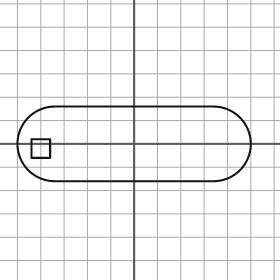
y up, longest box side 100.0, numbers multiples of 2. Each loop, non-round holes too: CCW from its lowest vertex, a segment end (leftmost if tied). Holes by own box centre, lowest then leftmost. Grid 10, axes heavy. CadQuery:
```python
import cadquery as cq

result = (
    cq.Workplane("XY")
    .moveTo(-34.0, -16.0)
    .lineTo(34.0, -16.0)
    .threePointArc((50.0, 0.0), (34.0, 16.0))
    .lineTo(-34.0, 16.0)
    .threePointArc((-50.0, 0.0), (-34.0, -16.0))
    .close()
    .moveTo(-44.0, -6.0)
    .lineTo(-36.0, -6.0)
    .lineTo(-36.0, 2.0)
    .lineTo(-44.0, 2.0)
    .close()
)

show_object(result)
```